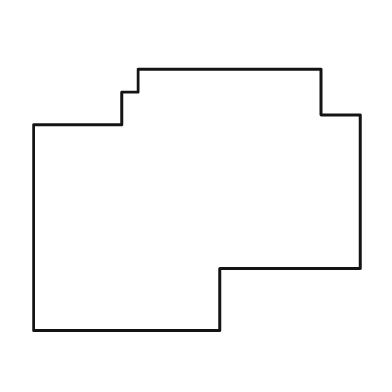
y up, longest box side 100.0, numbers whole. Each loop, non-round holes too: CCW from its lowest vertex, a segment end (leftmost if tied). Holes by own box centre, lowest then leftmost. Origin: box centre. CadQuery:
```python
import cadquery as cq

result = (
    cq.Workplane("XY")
    .moveTo(-50.0, -40.0)
    .lineTo(7.0, -40.0)
    .lineTo(7.0, -21.0)
    .lineTo(50.0, -21.0)
    .lineTo(50.0, 26.0)
    .lineTo(38.0, 26.0)
    .lineTo(38.0, 40.0)
    .lineTo(-18.0, 40.0)
    .lineTo(-18.0, 33.0)
    .lineTo(-23.0, 33.0)
    .lineTo(-23.0, 23.0)
    .lineTo(-50.0, 23.0)
    .close()
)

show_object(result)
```